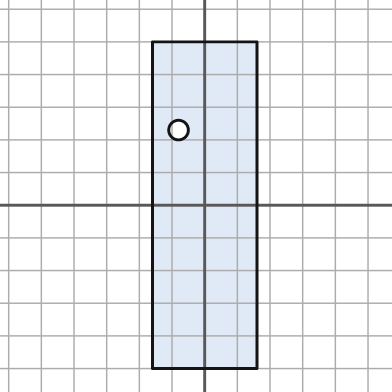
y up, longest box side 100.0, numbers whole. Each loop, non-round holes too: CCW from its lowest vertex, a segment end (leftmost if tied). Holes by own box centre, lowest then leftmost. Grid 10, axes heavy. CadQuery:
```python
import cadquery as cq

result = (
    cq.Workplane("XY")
    .moveTo(-16.0, -50.0)
    .lineTo(16.0, -50.0)
    .lineTo(16.0, 50.0)
    .lineTo(-16.0, 50.0)
    .close()
    .moveTo(-8.0, 23.0)
    .circle(3.0)
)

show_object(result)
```